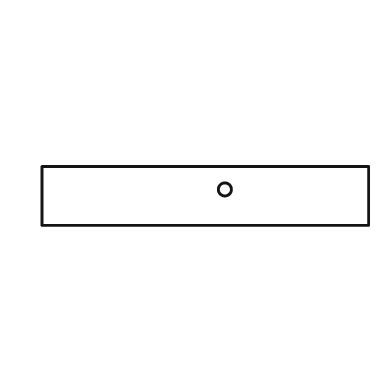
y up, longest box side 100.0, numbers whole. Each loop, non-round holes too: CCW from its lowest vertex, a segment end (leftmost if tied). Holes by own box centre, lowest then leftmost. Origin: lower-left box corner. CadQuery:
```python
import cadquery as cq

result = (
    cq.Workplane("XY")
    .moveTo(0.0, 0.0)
    .lineTo(100.0, 0.0)
    .lineTo(100.0, 18.0)
    .lineTo(0.0, 18.0)
    .close()
    .moveTo(56.0, 11.0)
    .circle(2.0)
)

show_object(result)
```